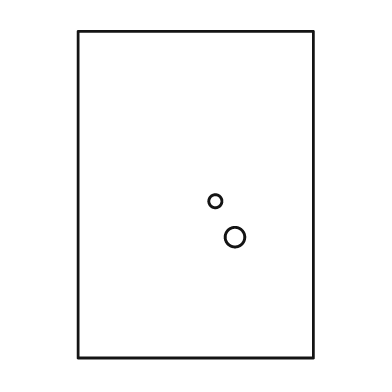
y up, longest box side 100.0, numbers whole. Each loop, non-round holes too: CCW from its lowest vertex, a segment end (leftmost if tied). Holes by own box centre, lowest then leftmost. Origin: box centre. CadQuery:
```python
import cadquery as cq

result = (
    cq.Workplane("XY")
    .moveTo(-36.0, -50.0)
    .lineTo(36.0, -50.0)
    .lineTo(36.0, 50.0)
    .lineTo(-36.0, 50.0)
    .close()
    .moveTo(12.0, -13.0)
    .circle(3.0)
    .moveTo(6.0, -2.0)
    .circle(2.0)
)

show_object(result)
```